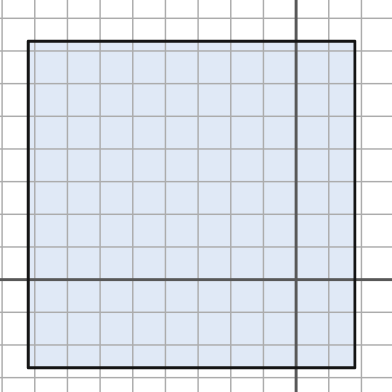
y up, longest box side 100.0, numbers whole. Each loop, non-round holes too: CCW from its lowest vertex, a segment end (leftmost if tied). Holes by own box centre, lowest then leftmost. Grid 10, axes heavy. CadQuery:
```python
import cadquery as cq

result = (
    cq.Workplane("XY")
    .moveTo(-82.0, -27.0)
    .lineTo(18.0, -27.0)
    .lineTo(18.0, 73.0)
    .lineTo(-82.0, 73.0)
    .close()
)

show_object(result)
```